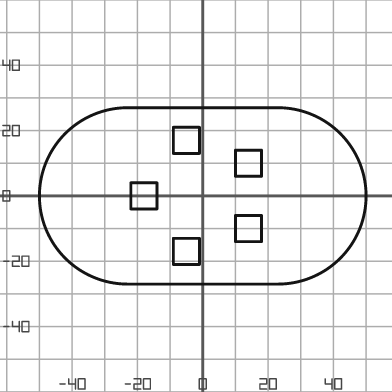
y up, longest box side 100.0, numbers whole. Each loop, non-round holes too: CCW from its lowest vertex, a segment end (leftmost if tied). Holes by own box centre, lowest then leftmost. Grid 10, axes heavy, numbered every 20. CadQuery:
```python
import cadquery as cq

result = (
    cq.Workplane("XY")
    .moveTo(-23.0, -27.0)
    .lineTo(23.0, -27.0)
    .threePointArc((50.0, 0.0), (23.0, 27.0))
    .lineTo(-23.0, 27.0)
    .threePointArc((-50.0, 0.0), (-23.0, -27.0))
    .close()
    .moveTo(-9.0, -21.0)
    .lineTo(-1.0, -21.0)
    .lineTo(-1.0, -13.0)
    .lineTo(-9.0, -13.0)
    .close()
    .moveTo(10.0, -14.0)
    .lineTo(18.0, -14.0)
    .lineTo(18.0, -6.0)
    .lineTo(10.0, -6.0)
    .close()
    .moveTo(-22.0, -4.0)
    .lineTo(-14.0, -4.0)
    .lineTo(-14.0, 4.0)
    .lineTo(-22.0, 4.0)
    .close()
    .moveTo(10.0, 6.0)
    .lineTo(18.0, 6.0)
    .lineTo(18.0, 14.0)
    .lineTo(10.0, 14.0)
    .close()
    .moveTo(-9.0, 13.0)
    .lineTo(-1.0, 13.0)
    .lineTo(-1.0, 21.0)
    .lineTo(-9.0, 21.0)
    .close()
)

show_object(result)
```